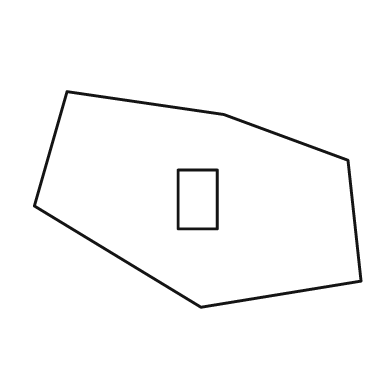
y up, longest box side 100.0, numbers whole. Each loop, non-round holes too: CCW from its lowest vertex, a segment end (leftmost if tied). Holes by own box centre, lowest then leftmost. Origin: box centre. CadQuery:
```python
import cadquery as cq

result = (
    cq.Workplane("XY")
    .moveTo(1.0, -33.0)
    .lineTo(50.0, -25.0)
    .lineTo(46.0, 12.0)
    .lineTo(8.0, 26.0)
    .lineTo(-40.0, 33.0)
    .lineTo(-50.0, -2.0)
    .close()
    .moveTo(-6.0, -9.0)
    .lineTo(6.0, -9.0)
    .lineTo(6.0, 9.0)
    .lineTo(-6.0, 9.0)
    .close()
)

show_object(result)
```